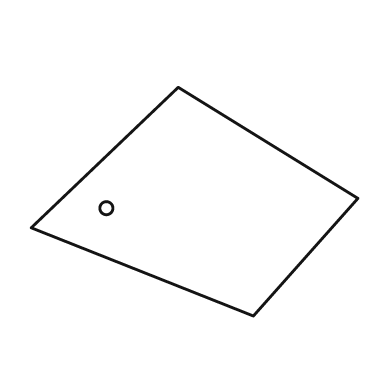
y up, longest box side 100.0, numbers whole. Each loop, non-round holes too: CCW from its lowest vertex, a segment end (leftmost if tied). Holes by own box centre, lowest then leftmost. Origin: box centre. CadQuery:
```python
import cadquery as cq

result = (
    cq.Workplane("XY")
    .moveTo(18.0, -35.0)
    .lineTo(50.0, 1.0)
    .lineTo(-5.0, 35.0)
    .lineTo(-50.0, -8.0)
    .close()
    .moveTo(-27.0, -2.0)
    .circle(2.0)
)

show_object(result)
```